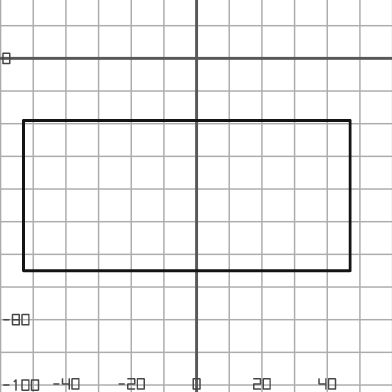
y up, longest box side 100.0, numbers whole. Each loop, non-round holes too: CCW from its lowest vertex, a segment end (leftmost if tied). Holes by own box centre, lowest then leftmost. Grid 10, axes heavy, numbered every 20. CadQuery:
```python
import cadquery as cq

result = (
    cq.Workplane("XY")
    .moveTo(-53.0, -65.0)
    .lineTo(47.0, -65.0)
    .lineTo(47.0, -19.0)
    .lineTo(-53.0, -19.0)
    .close()
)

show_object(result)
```